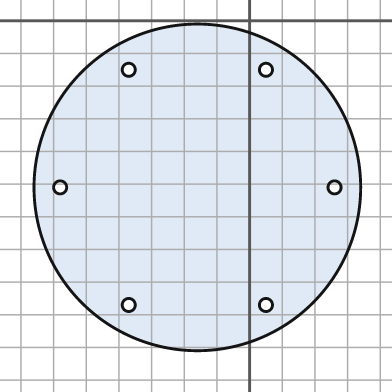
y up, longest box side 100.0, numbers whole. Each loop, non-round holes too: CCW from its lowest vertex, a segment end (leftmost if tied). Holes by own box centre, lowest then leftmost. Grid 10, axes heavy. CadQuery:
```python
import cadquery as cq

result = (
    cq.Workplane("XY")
    .moveTo(-16.0, -51.0)
    .circle(50.0)
    .moveTo(-37.0, -87.0)
    .circle(2.0)
    .moveTo(5.0, -87.0)
    .circle(2.0)
    .moveTo(-58.0, -51.0)
    .circle(2.0)
    .moveTo(26.0, -51.0)
    .circle(2.0)
    .moveTo(-37.0, -15.0)
    .circle(2.0)
    .moveTo(5.0, -15.0)
    .circle(2.0)
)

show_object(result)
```